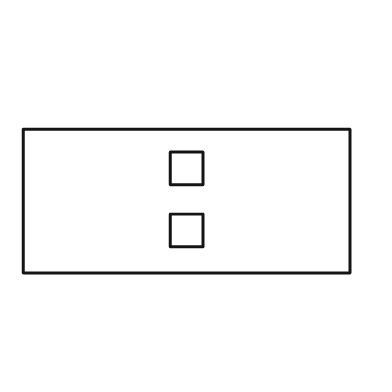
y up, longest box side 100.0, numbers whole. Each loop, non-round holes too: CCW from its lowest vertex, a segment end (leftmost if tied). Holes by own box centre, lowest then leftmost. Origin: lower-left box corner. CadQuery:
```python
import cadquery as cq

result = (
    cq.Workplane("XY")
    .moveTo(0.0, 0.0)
    .lineTo(100.0, 0.0)
    .lineTo(100.0, 44.0)
    .lineTo(0.0, 44.0)
    .close()
    .moveTo(45.0, 8.0)
    .lineTo(55.0, 8.0)
    .lineTo(55.0, 18.0)
    .lineTo(45.0, 18.0)
    .close()
    .moveTo(45.0, 27.0)
    .lineTo(55.0, 27.0)
    .lineTo(55.0, 37.0)
    .lineTo(45.0, 37.0)
    .close()
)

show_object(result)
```